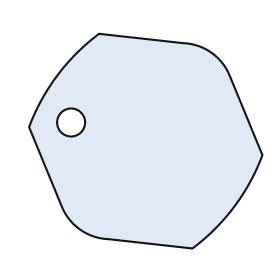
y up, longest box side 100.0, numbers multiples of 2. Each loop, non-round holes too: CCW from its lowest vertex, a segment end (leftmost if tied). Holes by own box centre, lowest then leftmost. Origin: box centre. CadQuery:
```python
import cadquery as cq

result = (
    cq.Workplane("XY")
    .moveTo(20.0, -46.0)
    .threePointArc((38.0, -28.0), (50.0, -6.0))
    .lineTo(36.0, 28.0)
    .threePointArc((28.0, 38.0), (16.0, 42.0))
    .lineTo(-20.0, 46.0)
    .threePointArc((-38.0, 28.0), (-50.0, 6.0))
    .lineTo(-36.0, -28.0)
    .threePointArc((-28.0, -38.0), (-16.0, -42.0))
    .close()
    .moveTo(-32.0, 8.0)
    .circle(6.0)
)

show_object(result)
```